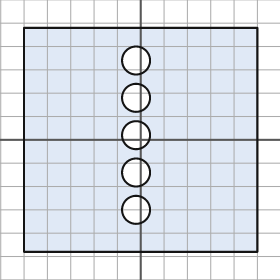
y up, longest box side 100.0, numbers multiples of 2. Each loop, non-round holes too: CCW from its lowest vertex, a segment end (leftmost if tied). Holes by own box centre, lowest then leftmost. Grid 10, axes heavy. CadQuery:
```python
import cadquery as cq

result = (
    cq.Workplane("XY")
    .moveTo(-50.0, -48.0)
    .lineTo(50.0, -48.0)
    .lineTo(50.0, 48.0)
    .lineTo(-50.0, 48.0)
    .close()
    .moveTo(-2.0, -30.0)
    .circle(6.0)
    .moveTo(-2.0, -14.0)
    .circle(6.0)
    .moveTo(-2.0, 2.0)
    .circle(6.0)
    .moveTo(-2.0, 18.0)
    .circle(6.0)
    .moveTo(-2.0, 34.0)
    .circle(6.0)
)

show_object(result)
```